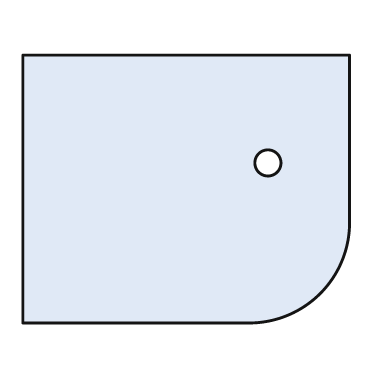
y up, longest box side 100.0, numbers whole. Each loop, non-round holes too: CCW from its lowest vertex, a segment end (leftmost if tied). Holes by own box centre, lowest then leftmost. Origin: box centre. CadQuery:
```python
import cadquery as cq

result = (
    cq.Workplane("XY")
    .moveTo(-50.0, -41.0)
    .lineTo(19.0, -41.0)
    .threePointArc((41.0, -32.0), (50.0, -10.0))
    .lineTo(50.0, 41.0)
    .lineTo(-50.0, 41.0)
    .close()
    .moveTo(25.0, 8.0)
    .circle(4.0)
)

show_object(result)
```